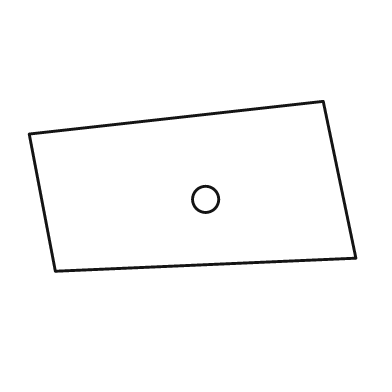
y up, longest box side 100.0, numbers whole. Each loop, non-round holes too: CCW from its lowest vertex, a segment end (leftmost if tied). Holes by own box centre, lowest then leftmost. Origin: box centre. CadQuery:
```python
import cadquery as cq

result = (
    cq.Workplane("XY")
    .moveTo(-42.0, -26.0)
    .lineTo(50.0, -22.0)
    .lineTo(40.0, 26.0)
    .lineTo(-50.0, 16.0)
    .close()
    .moveTo(4.0, -4.0)
    .circle(4.0)
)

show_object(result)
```